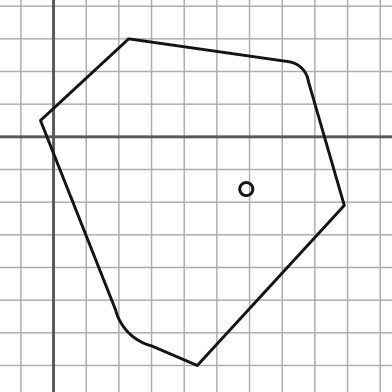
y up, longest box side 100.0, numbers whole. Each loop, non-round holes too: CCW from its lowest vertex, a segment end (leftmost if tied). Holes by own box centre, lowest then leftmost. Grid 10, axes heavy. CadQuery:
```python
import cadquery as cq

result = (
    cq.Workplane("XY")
    .moveTo(44.0, -70.0)
    .lineTo(89.0, -21.0)
    .lineTo(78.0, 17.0)
    .threePointArc((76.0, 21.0), (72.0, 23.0))
    .lineTo(23.0, 30.0)
    .lineTo(-4.0, 5.0)
    .lineTo(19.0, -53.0)
    .threePointArc((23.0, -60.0), (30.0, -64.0))
    .close()
    .moveTo(59.0, -16.0)
    .circle(2.0)
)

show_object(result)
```